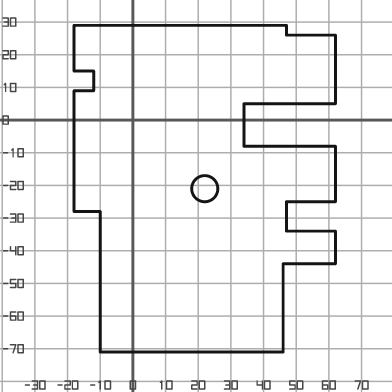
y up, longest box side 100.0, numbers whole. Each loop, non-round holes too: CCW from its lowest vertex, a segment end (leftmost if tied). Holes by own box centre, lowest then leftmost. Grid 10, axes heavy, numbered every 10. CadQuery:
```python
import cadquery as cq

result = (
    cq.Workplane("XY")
    .moveTo(-10.0, -71.0)
    .lineTo(46.0, -71.0)
    .lineTo(46.0, -44.0)
    .lineTo(62.0, -44.0)
    .lineTo(62.0, -34.0)
    .lineTo(47.0, -34.0)
    .lineTo(47.0, -25.0)
    .lineTo(62.0, -25.0)
    .lineTo(62.0, -8.0)
    .lineTo(34.0, -8.0)
    .lineTo(34.0, 5.0)
    .lineTo(62.0, 5.0)
    .lineTo(62.0, 26.0)
    .lineTo(47.0, 26.0)
    .lineTo(47.0, 29.0)
    .lineTo(-18.0, 29.0)
    .lineTo(-18.0, 15.0)
    .lineTo(-12.0, 15.0)
    .lineTo(-12.0, 9.0)
    .lineTo(-18.0, 9.0)
    .lineTo(-18.0, -28.0)
    .lineTo(-10.0, -28.0)
    .close()
    .moveTo(22.0, -21.0)
    .circle(4.0)
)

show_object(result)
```